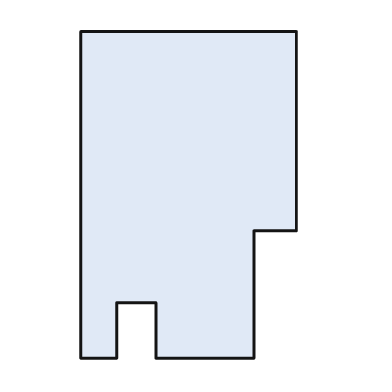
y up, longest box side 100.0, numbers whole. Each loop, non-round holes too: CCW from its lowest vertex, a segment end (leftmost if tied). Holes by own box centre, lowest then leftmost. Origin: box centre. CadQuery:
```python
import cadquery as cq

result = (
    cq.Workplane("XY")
    .moveTo(-33.0, -50.0)
    .lineTo(-22.0, -50.0)
    .lineTo(-22.0, -33.0)
    .lineTo(-10.0, -33.0)
    .lineTo(-10.0, -50.0)
    .lineTo(20.0, -50.0)
    .lineTo(20.0, -11.0)
    .lineTo(33.0, -11.0)
    .lineTo(33.0, 50.0)
    .lineTo(-33.0, 50.0)
    .close()
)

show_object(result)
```